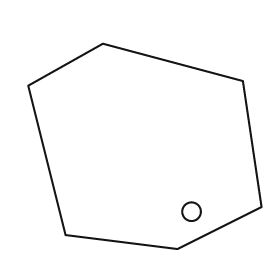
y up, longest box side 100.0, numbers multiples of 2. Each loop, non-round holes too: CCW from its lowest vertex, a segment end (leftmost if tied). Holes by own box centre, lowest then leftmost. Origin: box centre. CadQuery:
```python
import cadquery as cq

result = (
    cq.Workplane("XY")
    .moveTo(14.0, -44.0)
    .lineTo(50.0, -26.0)
    .lineTo(42.0, 28.0)
    .lineTo(-18.0, 44.0)
    .lineTo(-50.0, 26.0)
    .lineTo(-34.0, -38.0)
    .close()
    .moveTo(20.0, -28.0)
    .circle(4.0)
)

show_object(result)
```